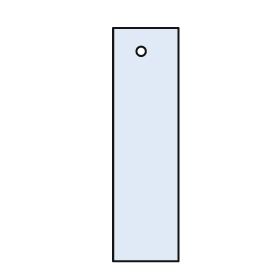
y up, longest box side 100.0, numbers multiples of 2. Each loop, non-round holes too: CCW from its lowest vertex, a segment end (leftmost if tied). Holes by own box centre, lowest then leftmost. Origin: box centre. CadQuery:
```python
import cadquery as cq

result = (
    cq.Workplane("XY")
    .moveTo(-14.0, -50.0)
    .lineTo(14.0, -50.0)
    .lineTo(14.0, 50.0)
    .lineTo(-14.0, 50.0)
    .close()
    .moveTo(-2.0, 40.0)
    .circle(2.0)
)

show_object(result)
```